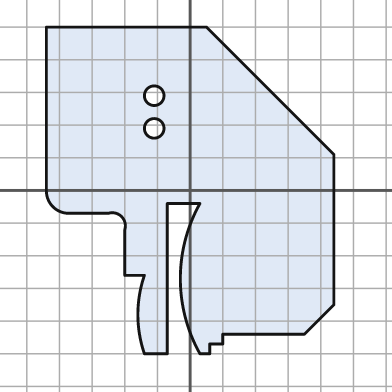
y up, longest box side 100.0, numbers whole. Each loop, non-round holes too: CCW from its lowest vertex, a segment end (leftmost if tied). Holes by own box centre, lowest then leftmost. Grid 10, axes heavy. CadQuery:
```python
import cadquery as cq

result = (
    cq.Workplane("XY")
    .moveTo(-14.0, -50.0)
    .lineTo(-7.0, -50.0)
    .lineTo(-7.0, -4.0)
    .lineTo(3.0, -4.0)
    .threePointArc((-3.0, -27.0), (3.0, -50.0))
    .lineTo(6.0, -50.0)
    .lineTo(6.0, -47.0)
    .lineTo(10.0, -47.0)
    .lineTo(10.0, -44.0)
    .lineTo(35.0, -44.0)
    .lineTo(44.0, -35.0)
    .lineTo(44.0, 11.0)
    .lineTo(5.0, 50.0)
    .lineTo(-44.0, 50.0)
    .lineTo(-44.0, 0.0)
    .threePointArc((-42.0, -5.0), (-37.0, -7.0))
    .lineTo(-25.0, -7.0)
    .threePointArc((-21.0, -8.0), (-20.0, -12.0))
    .lineTo(-20.0, -26.0)
    .lineTo(-14.0, -26.0)
    .threePointArc((-16.0, -38.0), (-14.0, -50.0))
    .close()
    .moveTo(-11.0, 19.0)
    .circle(3.0)
    .moveTo(-11.0, 29.0)
    .circle(3.0)
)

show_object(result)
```